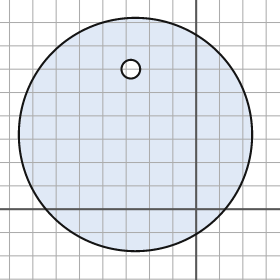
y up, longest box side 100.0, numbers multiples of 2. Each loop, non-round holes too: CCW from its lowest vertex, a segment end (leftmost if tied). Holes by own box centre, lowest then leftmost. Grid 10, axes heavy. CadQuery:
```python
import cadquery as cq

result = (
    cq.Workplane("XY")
    .moveTo(-26.0, 32.0)
    .circle(50.0)
    .moveTo(-28.0, 60.0)
    .circle(4.0)
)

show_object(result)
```